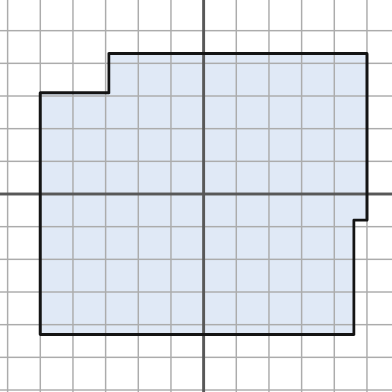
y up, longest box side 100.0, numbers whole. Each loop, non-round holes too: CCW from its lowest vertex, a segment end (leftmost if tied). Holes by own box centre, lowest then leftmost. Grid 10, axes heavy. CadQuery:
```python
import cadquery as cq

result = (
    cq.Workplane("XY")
    .moveTo(-50.0, -43.0)
    .lineTo(46.0, -43.0)
    .lineTo(46.0, -8.0)
    .lineTo(50.0, -8.0)
    .lineTo(50.0, 43.0)
    .lineTo(-29.0, 43.0)
    .lineTo(-29.0, 31.0)
    .lineTo(-50.0, 31.0)
    .close()
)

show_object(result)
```